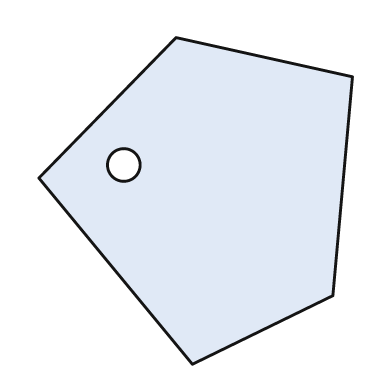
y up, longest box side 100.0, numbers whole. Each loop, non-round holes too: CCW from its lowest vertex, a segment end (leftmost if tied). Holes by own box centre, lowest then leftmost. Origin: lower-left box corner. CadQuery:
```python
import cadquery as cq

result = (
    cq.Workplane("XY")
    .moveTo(47.0, 0.0)
    .lineTo(90.0, 21.0)
    .lineTo(96.0, 88.0)
    .lineTo(42.0, 100.0)
    .lineTo(0.0, 57.0)
    .close()
    .moveTo(26.0, 61.0)
    .circle(5.0)
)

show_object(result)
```